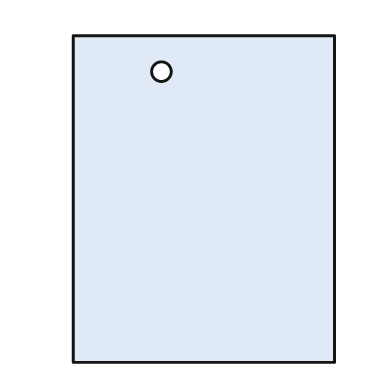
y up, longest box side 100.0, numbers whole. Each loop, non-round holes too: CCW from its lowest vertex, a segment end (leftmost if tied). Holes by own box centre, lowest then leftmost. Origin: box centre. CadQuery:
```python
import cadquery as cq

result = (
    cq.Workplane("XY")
    .moveTo(-40.0, -50.0)
    .lineTo(40.0, -50.0)
    .lineTo(40.0, 50.0)
    .lineTo(-40.0, 50.0)
    .close()
    .moveTo(-13.0, 39.0)
    .circle(3.0)
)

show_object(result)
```